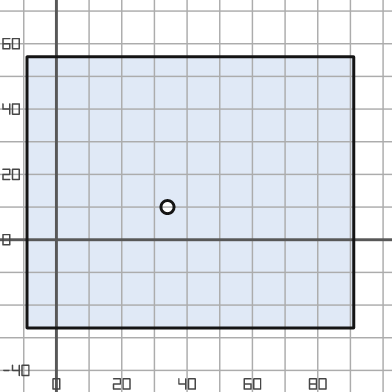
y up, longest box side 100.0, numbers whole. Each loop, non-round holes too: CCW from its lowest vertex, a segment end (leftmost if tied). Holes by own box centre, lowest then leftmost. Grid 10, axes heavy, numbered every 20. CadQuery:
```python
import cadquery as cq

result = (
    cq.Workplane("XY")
    .moveTo(-9.0, -27.0)
    .lineTo(91.0, -27.0)
    .lineTo(91.0, 56.0)
    .lineTo(-9.0, 56.0)
    .close()
    .moveTo(34.0, 10.0)
    .circle(2.0)
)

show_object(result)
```